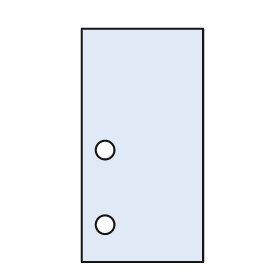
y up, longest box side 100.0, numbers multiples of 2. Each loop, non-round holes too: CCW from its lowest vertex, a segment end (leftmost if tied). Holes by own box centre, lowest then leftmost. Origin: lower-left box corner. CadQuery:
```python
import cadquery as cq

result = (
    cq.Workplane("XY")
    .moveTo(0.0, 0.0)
    .lineTo(52.0, 0.0)
    .lineTo(52.0, 100.0)
    .lineTo(0.0, 100.0)
    .close()
    .moveTo(10.0, 16.0)
    .circle(4.0)
    .moveTo(10.0, 48.0)
    .circle(4.0)
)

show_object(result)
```